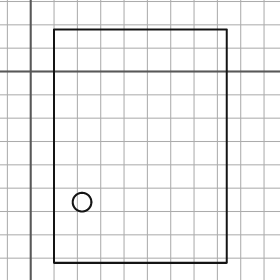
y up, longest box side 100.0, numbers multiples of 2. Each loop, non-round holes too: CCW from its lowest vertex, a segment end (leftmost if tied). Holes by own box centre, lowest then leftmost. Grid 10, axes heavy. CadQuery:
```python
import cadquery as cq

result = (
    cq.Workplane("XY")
    .moveTo(10.0, -82.0)
    .lineTo(84.0, -82.0)
    .lineTo(84.0, 18.0)
    .lineTo(10.0, 18.0)
    .close()
    .moveTo(22.0, -56.0)
    .circle(4.0)
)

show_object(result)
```